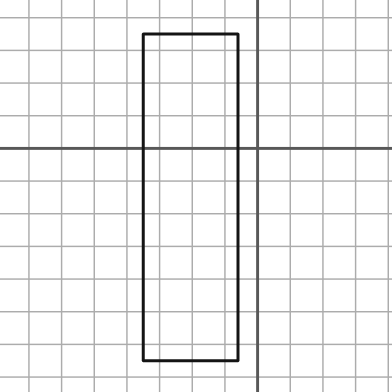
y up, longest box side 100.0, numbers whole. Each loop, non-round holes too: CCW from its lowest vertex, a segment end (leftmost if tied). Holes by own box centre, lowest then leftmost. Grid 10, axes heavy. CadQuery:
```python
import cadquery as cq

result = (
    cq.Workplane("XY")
    .moveTo(-35.0, -65.0)
    .lineTo(-6.0, -65.0)
    .lineTo(-6.0, 35.0)
    .lineTo(-35.0, 35.0)
    .close()
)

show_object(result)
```